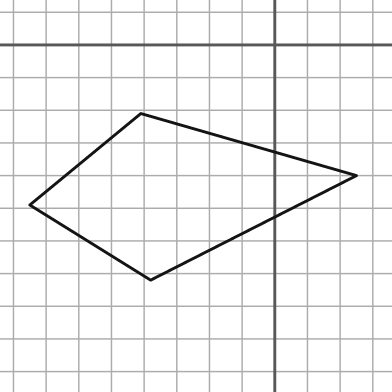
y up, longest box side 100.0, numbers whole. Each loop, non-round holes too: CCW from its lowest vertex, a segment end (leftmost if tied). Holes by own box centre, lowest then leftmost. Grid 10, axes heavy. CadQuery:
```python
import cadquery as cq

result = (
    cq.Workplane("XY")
    .moveTo(-38.0, -72.0)
    .lineTo(25.0, -40.0)
    .lineTo(-41.0, -21.0)
    .lineTo(-75.0, -49.0)
    .close()
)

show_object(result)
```